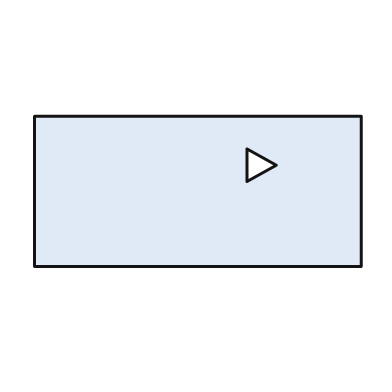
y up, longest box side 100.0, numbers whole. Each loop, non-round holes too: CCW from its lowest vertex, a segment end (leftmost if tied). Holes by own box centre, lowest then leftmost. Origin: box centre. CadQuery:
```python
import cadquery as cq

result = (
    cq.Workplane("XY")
    .moveTo(-50.0, -23.0)
    .lineTo(50.0, -23.0)
    .lineTo(50.0, 23.0)
    .lineTo(-50.0, 23.0)
    .close()
    .moveTo(15.0, 3.0)
    .lineTo(24.0, 8.0)
    .lineTo(15.0, 13.0)
    .close()
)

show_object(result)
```